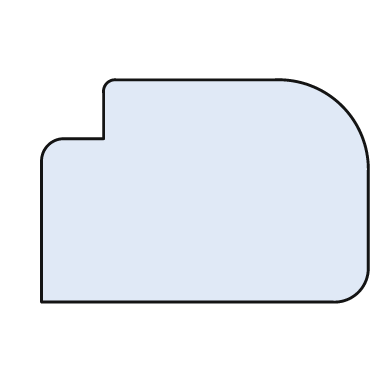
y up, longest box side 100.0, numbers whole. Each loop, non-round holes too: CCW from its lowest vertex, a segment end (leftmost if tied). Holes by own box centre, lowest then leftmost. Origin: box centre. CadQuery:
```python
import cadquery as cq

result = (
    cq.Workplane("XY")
    .moveTo(-50.0, -34.0)
    .lineTo(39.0, -34.0)
    .threePointArc((47.0, -31.0), (50.0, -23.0))
    .lineTo(50.0, 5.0)
    .threePointArc((42.0, 26.0), (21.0, 34.0))
    .lineTo(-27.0, 34.0)
    .threePointArc((-30.0, 33.0), (-31.0, 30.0))
    .lineTo(-31.0, 16.0)
    .lineTo(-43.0, 16.0)
    .threePointArc((-48.0, 14.0), (-50.0, 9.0))
    .close()
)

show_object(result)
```